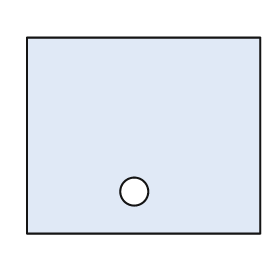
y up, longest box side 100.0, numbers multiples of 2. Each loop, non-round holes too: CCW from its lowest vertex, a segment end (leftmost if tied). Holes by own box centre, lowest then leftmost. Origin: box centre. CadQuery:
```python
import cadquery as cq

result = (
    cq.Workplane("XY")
    .moveTo(-50.0, -42.0)
    .lineTo(50.0, -42.0)
    .lineTo(50.0, 42.0)
    .lineTo(-50.0, 42.0)
    .close()
    .moveTo(-4.0, -24.0)
    .circle(6.0)
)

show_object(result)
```